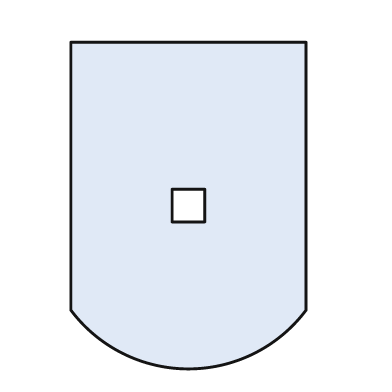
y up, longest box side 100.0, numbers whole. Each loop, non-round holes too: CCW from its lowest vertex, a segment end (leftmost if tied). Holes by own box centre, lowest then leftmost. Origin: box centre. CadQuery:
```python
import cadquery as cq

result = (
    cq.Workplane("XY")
    .moveTo(-36.0, -32.0)
    .threePointArc((0.0, -50.0), (36.0, -32.0))
    .lineTo(36.0, 50.0)
    .lineTo(-36.0, 50.0)
    .close()
    .moveTo(-5.0, -5.0)
    .lineTo(5.0, -5.0)
    .lineTo(5.0, 5.0)
    .lineTo(-5.0, 5.0)
    .close()
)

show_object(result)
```